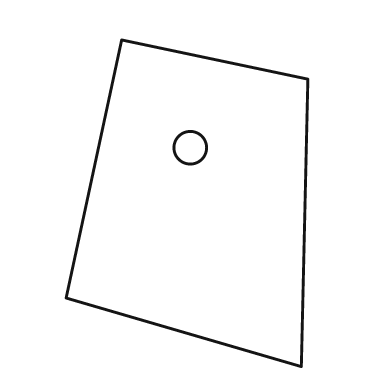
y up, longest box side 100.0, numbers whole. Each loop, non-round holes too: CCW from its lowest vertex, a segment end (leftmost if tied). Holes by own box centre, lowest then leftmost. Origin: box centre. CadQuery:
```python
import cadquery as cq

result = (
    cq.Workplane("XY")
    .moveTo(35.0, -50.0)
    .lineTo(37.0, 38.0)
    .lineTo(-20.0, 50.0)
    .lineTo(-37.0, -29.0)
    .close()
    .moveTo(1.0, 17.0)
    .circle(5.0)
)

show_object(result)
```